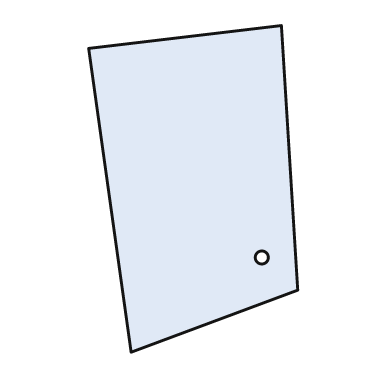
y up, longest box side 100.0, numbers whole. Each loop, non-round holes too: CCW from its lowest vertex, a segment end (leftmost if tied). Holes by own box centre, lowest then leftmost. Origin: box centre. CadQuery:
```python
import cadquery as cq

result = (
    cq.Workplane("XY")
    .moveTo(-19.0, -50.0)
    .lineTo(32.0, -31.0)
    .lineTo(27.0, 50.0)
    .lineTo(-32.0, 43.0)
    .close()
    .moveTo(21.0, -21.0)
    .circle(2.0)
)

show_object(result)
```